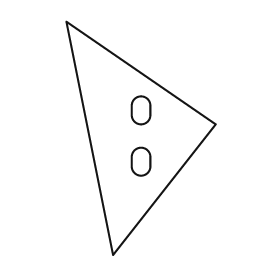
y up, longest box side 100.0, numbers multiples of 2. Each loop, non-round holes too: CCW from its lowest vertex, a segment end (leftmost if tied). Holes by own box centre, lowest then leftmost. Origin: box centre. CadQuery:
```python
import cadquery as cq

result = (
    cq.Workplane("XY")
    .moveTo(-12.0, -50.0)
    .lineTo(32.0, 6.0)
    .lineTo(-32.0, 50.0)
    .close()
    .moveTo(-4.0, -12.0)
    .threePointArc((0.0, -16.0), (4.0, -12.0))
    .lineTo(4.0, -8.0)
    .threePointArc((0.0, -4.0), (-4.0, -8.0))
    .close()
    .moveTo(-4.0, 10.0)
    .threePointArc((0.0, 6.0), (4.0, 10.0))
    .lineTo(4.0, 14.0)
    .threePointArc((0.0, 18.0), (-4.0, 14.0))
    .close()
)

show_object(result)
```